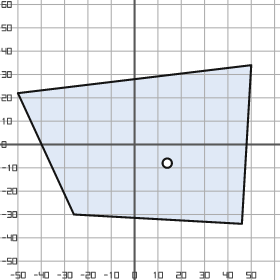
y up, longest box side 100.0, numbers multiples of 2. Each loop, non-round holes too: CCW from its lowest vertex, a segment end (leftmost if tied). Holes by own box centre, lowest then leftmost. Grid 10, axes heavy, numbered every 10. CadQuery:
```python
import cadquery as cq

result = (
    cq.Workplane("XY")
    .moveTo(46.0, -34.0)
    .lineTo(50.0, 34.0)
    .lineTo(-50.0, 22.0)
    .lineTo(-26.0, -30.0)
    .close()
    .moveTo(14.0, -8.0)
    .circle(2.0)
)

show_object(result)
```